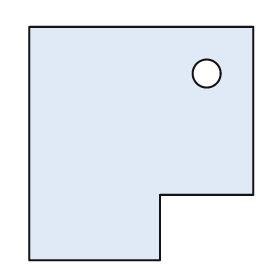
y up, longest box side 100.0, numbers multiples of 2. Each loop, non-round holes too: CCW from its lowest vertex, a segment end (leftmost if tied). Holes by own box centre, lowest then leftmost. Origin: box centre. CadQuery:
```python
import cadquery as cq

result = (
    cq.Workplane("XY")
    .moveTo(-48.0, -50.0)
    .lineTo(8.0, -50.0)
    .lineTo(8.0, -22.0)
    .lineTo(48.0, -22.0)
    .lineTo(48.0, 50.0)
    .lineTo(-48.0, 50.0)
    .close()
    .moveTo(28.0, 30.0)
    .circle(6.0)
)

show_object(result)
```